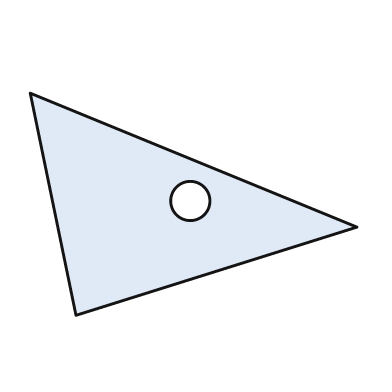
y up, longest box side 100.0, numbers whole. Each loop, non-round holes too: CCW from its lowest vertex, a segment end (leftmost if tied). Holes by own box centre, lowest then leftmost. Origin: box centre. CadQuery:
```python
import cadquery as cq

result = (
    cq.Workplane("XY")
    .moveTo(-36.0, -34.0)
    .lineTo(50.0, -7.0)
    .lineTo(-50.0, 34.0)
    .close()
    .moveTo(-1.0, 1.0)
    .circle(6.0)
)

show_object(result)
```